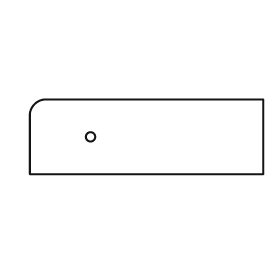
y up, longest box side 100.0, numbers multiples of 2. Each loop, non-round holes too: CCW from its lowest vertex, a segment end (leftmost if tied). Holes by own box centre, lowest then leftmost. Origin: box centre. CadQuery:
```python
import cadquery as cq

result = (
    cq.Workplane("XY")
    .moveTo(-50.0, -16.0)
    .lineTo(50.0, -16.0)
    .lineTo(50.0, 16.0)
    .lineTo(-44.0, 16.0)
    .threePointArc((-48.0, 14.0), (-50.0, 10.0))
    .close()
    .moveTo(-24.0, 0.0)
    .circle(2.0)
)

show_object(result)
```